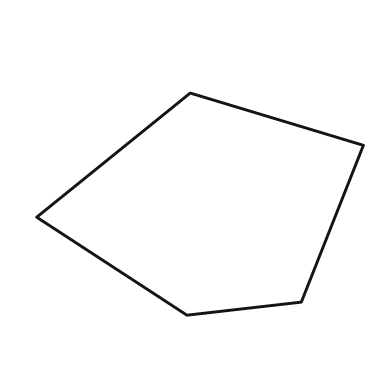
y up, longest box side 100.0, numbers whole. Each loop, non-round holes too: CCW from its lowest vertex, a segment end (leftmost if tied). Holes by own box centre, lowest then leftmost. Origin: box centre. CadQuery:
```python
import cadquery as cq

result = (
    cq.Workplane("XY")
    .moveTo(-4.0, -34.0)
    .lineTo(31.0, -30.0)
    .lineTo(50.0, 18.0)
    .lineTo(-3.0, 34.0)
    .lineTo(-50.0, -4.0)
    .close()
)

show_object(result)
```